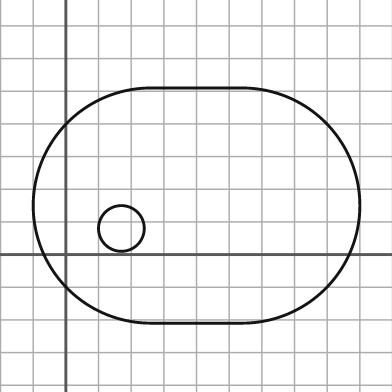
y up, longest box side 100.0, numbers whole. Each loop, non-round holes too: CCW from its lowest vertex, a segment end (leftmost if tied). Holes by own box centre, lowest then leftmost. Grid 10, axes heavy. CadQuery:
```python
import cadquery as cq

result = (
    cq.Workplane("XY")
    .moveTo(26.0, -21.0)
    .lineTo(54.0, -21.0)
    .threePointArc((90.0, 15.0), (54.0, 51.0))
    .lineTo(26.0, 51.0)
    .threePointArc((-10.0, 15.0), (26.0, -21.0))
    .close()
    .moveTo(17.0, 8.0)
    .circle(7.0)
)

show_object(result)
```